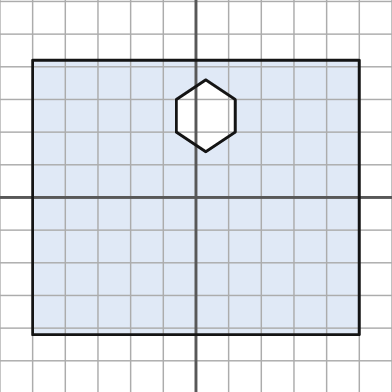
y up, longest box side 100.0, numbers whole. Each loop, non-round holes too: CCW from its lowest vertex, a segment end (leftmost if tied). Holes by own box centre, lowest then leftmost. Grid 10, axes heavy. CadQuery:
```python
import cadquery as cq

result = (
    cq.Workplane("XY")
    .moveTo(-50.0, -42.0)
    .lineTo(50.0, -42.0)
    .lineTo(50.0, 42.0)
    .lineTo(-50.0, 42.0)
    .close()
    .moveTo(3.0, 14.0)
    .lineTo(12.0, 20.0)
    .lineTo(12.0, 30.0)
    .lineTo(3.0, 36.0)
    .lineTo(-6.0, 30.0)
    .lineTo(-6.0, 20.0)
    .close()
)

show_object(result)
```